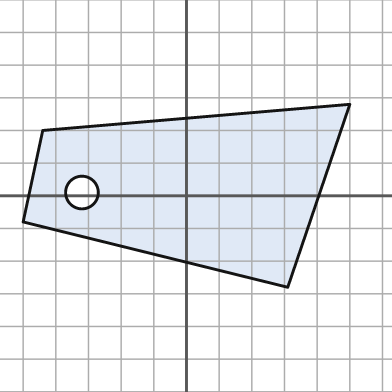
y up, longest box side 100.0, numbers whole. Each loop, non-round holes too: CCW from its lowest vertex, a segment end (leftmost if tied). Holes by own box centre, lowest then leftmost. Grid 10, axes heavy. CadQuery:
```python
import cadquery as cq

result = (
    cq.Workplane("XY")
    .moveTo(31.0, -28.0)
    .lineTo(50.0, 28.0)
    .lineTo(-44.0, 20.0)
    .lineTo(-50.0, -8.0)
    .close()
    .moveTo(-32.0, 1.0)
    .circle(5.0)
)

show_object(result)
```